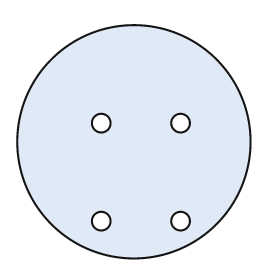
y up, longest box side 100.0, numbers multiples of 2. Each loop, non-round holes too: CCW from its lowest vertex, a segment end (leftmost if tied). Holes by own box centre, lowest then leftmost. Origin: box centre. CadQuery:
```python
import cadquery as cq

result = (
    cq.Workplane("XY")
    .moveTo(0.0, 0.0)
    .circle(50.0)
    .moveTo(-14.0, -34.0)
    .circle(4.0)
    .moveTo(20.0, -34.0)
    .circle(4.0)
    .moveTo(-14.0, 8.0)
    .circle(4.0)
    .moveTo(20.0, 8.0)
    .circle(4.0)
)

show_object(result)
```